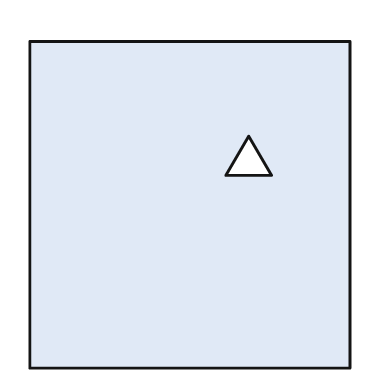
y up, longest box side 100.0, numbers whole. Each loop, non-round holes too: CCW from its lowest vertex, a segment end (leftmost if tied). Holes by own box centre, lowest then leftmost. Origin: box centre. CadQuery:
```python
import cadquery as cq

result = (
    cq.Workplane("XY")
    .moveTo(-49.0, -50.0)
    .lineTo(49.0, -50.0)
    .lineTo(49.0, 50.0)
    .lineTo(-49.0, 50.0)
    .close()
    .moveTo(11.0, 9.0)
    .lineTo(25.0, 9.0)
    .lineTo(18.0, 21.0)
    .close()
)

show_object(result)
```